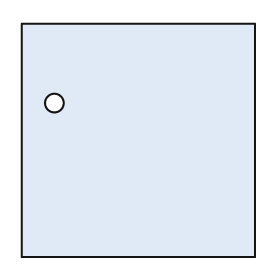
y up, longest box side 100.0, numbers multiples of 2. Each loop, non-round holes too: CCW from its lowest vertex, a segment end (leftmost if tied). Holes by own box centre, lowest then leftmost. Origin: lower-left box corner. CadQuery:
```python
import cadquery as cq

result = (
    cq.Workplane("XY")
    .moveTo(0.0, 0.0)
    .lineTo(100.0, 0.0)
    .lineTo(100.0, 100.0)
    .lineTo(0.0, 100.0)
    .close()
    .moveTo(14.0, 66.0)
    .circle(4.0)
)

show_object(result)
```